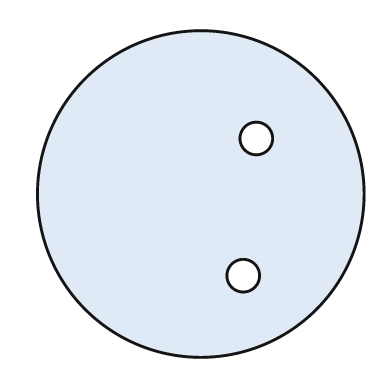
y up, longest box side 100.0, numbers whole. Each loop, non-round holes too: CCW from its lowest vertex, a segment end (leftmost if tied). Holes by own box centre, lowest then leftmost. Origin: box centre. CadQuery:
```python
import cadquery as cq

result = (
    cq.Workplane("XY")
    .moveTo(0.0, 0.0)
    .circle(50.0)
    .moveTo(13.0, -25.0)
    .circle(5.0)
    .moveTo(17.0, 17.0)
    .circle(5.0)
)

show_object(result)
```